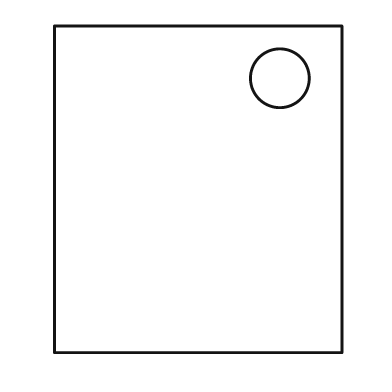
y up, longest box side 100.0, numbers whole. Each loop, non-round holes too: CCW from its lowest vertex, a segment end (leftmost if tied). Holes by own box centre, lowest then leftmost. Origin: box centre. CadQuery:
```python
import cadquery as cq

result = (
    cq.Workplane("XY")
    .moveTo(-44.0, -50.0)
    .lineTo(44.0, -50.0)
    .lineTo(44.0, 50.0)
    .lineTo(-44.0, 50.0)
    .close()
    .moveTo(25.0, 34.0)
    .circle(9.0)
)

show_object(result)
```